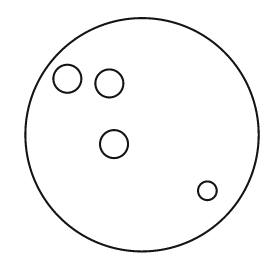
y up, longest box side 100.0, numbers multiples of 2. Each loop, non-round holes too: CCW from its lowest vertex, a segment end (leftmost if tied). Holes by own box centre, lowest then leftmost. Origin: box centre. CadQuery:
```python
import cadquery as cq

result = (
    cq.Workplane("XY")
    .moveTo(0.0, 0.0)
    .circle(50.0)
    .moveTo(28.0, -24.0)
    .circle(4.0)
    .moveTo(-12.0, -4.0)
    .circle(6.0)
    .moveTo(-14.0, 22.0)
    .circle(6.0)
    .moveTo(-32.0, 24.0)
    .circle(6.0)
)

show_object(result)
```